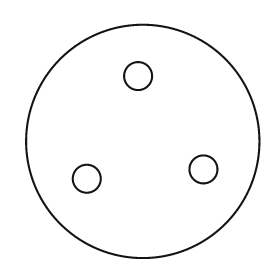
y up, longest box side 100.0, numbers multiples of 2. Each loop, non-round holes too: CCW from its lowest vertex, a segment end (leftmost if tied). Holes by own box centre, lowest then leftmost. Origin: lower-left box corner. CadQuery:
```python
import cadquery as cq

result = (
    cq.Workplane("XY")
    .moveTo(50.0, 50.0)
    .circle(50.0)
    .moveTo(26.0, 34.0)
    .circle(6.0)
    .moveTo(76.0, 38.0)
    .circle(6.0)
    .moveTo(48.0, 78.0)
    .circle(6.0)
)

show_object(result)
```